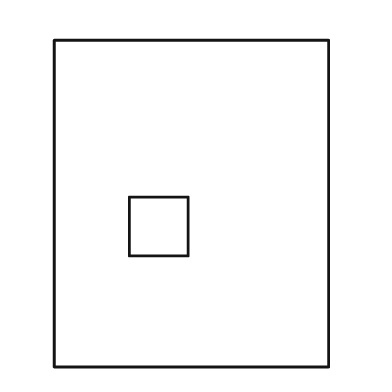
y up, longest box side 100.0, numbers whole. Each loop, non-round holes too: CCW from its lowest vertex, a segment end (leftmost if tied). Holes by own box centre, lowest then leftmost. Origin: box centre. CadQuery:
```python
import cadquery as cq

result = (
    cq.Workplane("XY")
    .moveTo(-42.0, -50.0)
    .lineTo(42.0, -50.0)
    .lineTo(42.0, 50.0)
    .lineTo(-42.0, 50.0)
    .close()
    .moveTo(-19.0, -16.0)
    .lineTo(-1.0, -16.0)
    .lineTo(-1.0, 2.0)
    .lineTo(-19.0, 2.0)
    .close()
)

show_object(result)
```